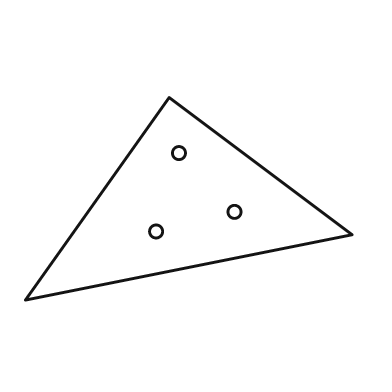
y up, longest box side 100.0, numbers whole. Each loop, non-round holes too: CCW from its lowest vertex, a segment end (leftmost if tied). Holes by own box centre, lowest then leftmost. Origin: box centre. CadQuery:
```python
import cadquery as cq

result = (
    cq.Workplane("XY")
    .moveTo(-50.0, -31.0)
    .lineTo(50.0, -11.0)
    .lineTo(-6.0, 31.0)
    .close()
    .moveTo(-10.0, -10.0)
    .circle(2.0)
    .moveTo(14.0, -4.0)
    .circle(2.0)
    .moveTo(-3.0, 14.0)
    .circle(2.0)
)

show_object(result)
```